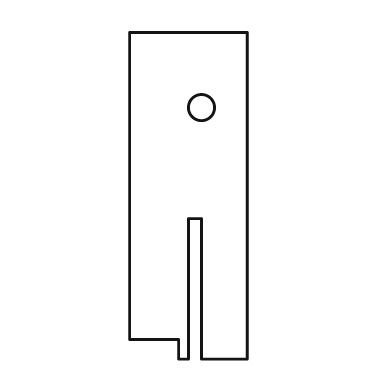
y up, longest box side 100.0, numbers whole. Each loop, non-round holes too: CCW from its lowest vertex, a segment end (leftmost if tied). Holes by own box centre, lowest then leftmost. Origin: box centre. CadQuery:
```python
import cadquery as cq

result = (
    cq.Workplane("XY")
    .moveTo(-3.0, -50.0)
    .lineTo(0.0, -50.0)
    .lineTo(0.0, -7.0)
    .lineTo(4.0, -7.0)
    .lineTo(4.0, -50.0)
    .lineTo(18.0, -50.0)
    .lineTo(18.0, 50.0)
    .lineTo(-18.0, 50.0)
    .lineTo(-18.0, -44.0)
    .lineTo(-3.0, -44.0)
    .close()
    .moveTo(4.0, 27.0)
    .circle(4.0)
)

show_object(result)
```